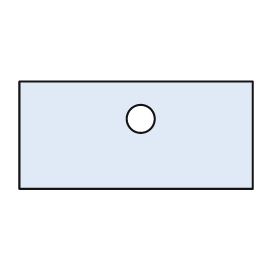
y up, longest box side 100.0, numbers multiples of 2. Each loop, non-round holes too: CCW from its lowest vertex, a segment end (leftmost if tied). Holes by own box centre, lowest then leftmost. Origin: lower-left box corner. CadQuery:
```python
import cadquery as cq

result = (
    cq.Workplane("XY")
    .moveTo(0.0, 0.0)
    .lineTo(100.0, 0.0)
    .lineTo(100.0, 46.0)
    .lineTo(0.0, 46.0)
    .close()
    .moveTo(52.0, 30.0)
    .circle(6.0)
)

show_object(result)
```